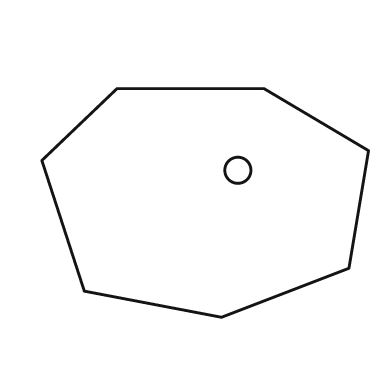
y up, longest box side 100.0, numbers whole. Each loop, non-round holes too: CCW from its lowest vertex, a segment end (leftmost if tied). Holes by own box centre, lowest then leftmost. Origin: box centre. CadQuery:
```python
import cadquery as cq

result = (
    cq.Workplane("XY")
    .moveTo(5.0, -35.0)
    .lineTo(44.0, -20.0)
    .lineTo(50.0, 16.0)
    .lineTo(18.0, 35.0)
    .lineTo(-27.0, 35.0)
    .lineTo(-50.0, 13.0)
    .lineTo(-37.0, -27.0)
    .close()
    .moveTo(10.0, 10.0)
    .circle(4.0)
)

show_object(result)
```